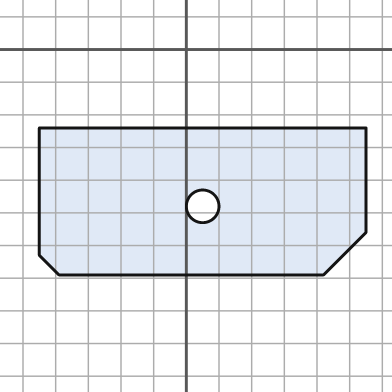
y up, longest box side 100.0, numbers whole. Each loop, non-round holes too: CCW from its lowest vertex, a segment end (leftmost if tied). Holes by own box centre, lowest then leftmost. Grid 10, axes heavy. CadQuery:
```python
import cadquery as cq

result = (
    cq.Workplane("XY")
    .moveTo(-39.0, -69.0)
    .lineTo(42.0, -69.0)
    .lineTo(55.0, -56.0)
    .lineTo(55.0, -24.0)
    .lineTo(-45.0, -24.0)
    .lineTo(-45.0, -63.0)
    .close()
    .moveTo(5.0, -48.0)
    .circle(5.0)
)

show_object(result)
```